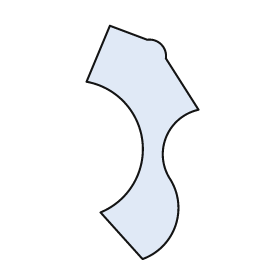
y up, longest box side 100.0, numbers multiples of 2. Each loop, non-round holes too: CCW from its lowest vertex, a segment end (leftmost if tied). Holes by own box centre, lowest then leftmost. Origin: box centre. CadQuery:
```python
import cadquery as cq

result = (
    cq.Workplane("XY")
    .moveTo(0.0, -50.0)
    .threePointArc((14.0, -36.0), (12.0, -16.0))
    .threePointArc((10.0, 2.0), (24.0, 14.0))
    .lineTo(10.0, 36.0)
    .threePointArc((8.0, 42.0), (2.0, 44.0))
    .lineTo(-14.0, 50.0)
    .lineTo(-24.0, 26.0)
    .threePointArc((0.0, 0.0), (-18.0, -30.0))
    .close()
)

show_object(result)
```